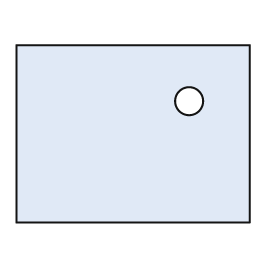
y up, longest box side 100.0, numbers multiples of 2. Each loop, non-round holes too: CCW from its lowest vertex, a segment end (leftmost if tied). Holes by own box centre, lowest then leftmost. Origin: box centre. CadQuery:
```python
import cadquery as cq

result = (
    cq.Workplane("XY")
    .moveTo(-50.0, -38.0)
    .lineTo(50.0, -38.0)
    .lineTo(50.0, 38.0)
    .lineTo(-50.0, 38.0)
    .close()
    .moveTo(24.0, 14.0)
    .circle(6.0)
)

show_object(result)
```